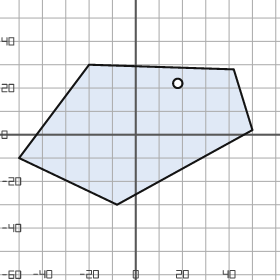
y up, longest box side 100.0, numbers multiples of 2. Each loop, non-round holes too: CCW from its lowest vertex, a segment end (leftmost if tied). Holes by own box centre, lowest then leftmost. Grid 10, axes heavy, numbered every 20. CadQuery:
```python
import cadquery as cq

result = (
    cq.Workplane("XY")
    .moveTo(-8.0, -30.0)
    .lineTo(50.0, 2.0)
    .lineTo(42.0, 28.0)
    .lineTo(-20.0, 30.0)
    .lineTo(-50.0, -10.0)
    .close()
    .moveTo(18.0, 22.0)
    .circle(2.0)
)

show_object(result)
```